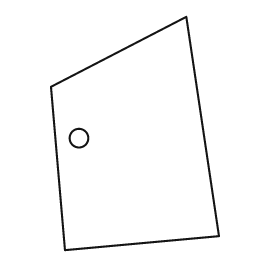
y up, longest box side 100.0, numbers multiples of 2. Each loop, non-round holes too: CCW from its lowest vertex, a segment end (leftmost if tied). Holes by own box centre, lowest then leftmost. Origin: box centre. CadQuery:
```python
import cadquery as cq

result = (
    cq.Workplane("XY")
    .moveTo(-30.0, -50.0)
    .lineTo(36.0, -44.0)
    .lineTo(22.0, 50.0)
    .lineTo(-36.0, 20.0)
    .close()
    .moveTo(-24.0, -2.0)
    .circle(4.0)
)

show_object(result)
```